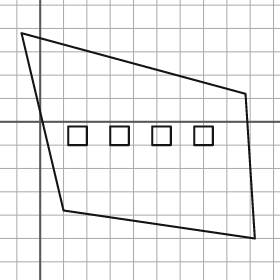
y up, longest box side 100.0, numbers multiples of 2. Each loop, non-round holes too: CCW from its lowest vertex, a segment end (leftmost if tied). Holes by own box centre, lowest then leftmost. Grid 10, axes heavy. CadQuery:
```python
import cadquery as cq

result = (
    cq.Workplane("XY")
    .moveTo(92.0, -50.0)
    .lineTo(88.0, 12.0)
    .lineTo(-8.0, 38.0)
    .lineTo(10.0, -38.0)
    .close()
    .moveTo(12.0, -10.0)
    .lineTo(20.0, -10.0)
    .lineTo(20.0, -2.0)
    .lineTo(12.0, -2.0)
    .close()
    .moveTo(30.0, -10.0)
    .lineTo(38.0, -10.0)
    .lineTo(38.0, -2.0)
    .lineTo(30.0, -2.0)
    .close()
    .moveTo(48.0, -10.0)
    .lineTo(56.0, -10.0)
    .lineTo(56.0, -2.0)
    .lineTo(48.0, -2.0)
    .close()
    .moveTo(66.0, -10.0)
    .lineTo(74.0, -10.0)
    .lineTo(74.0, -2.0)
    .lineTo(66.0, -2.0)
    .close()
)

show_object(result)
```